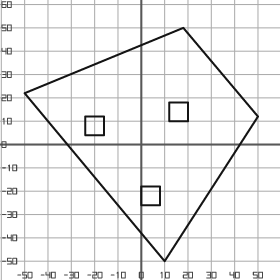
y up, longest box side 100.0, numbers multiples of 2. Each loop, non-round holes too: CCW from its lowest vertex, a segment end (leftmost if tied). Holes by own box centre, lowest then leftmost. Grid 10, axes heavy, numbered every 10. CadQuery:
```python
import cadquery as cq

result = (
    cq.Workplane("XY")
    .moveTo(10.0, -50.0)
    .lineTo(50.0, 12.0)
    .lineTo(18.0, 50.0)
    .lineTo(-50.0, 22.0)
    .close()
    .moveTo(0.0, -26.0)
    .lineTo(8.0, -26.0)
    .lineTo(8.0, -18.0)
    .lineTo(0.0, -18.0)
    .close()
    .moveTo(-24.0, 4.0)
    .lineTo(-16.0, 4.0)
    .lineTo(-16.0, 12.0)
    .lineTo(-24.0, 12.0)
    .close()
    .moveTo(12.0, 10.0)
    .lineTo(20.0, 10.0)
    .lineTo(20.0, 18.0)
    .lineTo(12.0, 18.0)
    .close()
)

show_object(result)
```